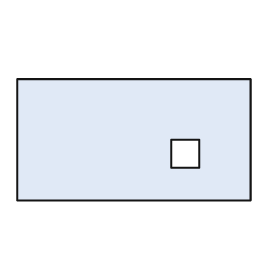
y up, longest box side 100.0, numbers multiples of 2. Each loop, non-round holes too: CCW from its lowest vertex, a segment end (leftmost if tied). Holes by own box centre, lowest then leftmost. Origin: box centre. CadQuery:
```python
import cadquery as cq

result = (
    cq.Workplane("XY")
    .moveTo(-50.0, -26.0)
    .lineTo(50.0, -26.0)
    .lineTo(50.0, 26.0)
    .lineTo(-50.0, 26.0)
    .close()
    .moveTo(16.0, -12.0)
    .lineTo(28.0, -12.0)
    .lineTo(28.0, 0.0)
    .lineTo(16.0, 0.0)
    .close()
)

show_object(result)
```